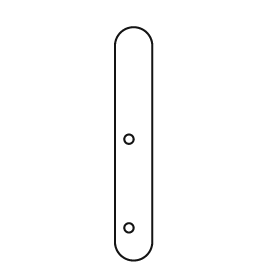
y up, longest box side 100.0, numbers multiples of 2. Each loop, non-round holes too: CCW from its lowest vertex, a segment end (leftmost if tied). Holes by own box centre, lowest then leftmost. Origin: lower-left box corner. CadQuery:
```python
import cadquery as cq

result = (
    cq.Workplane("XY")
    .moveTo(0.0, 8.0)
    .threePointArc((8.0, 0.0), (16.0, 8.0))
    .lineTo(16.0, 92.0)
    .threePointArc((8.0, 100.0), (0.0, 92.0))
    .close()
    .moveTo(6.0, 14.0)
    .circle(2.0)
    .moveTo(6.0, 52.0)
    .circle(2.0)
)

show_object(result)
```